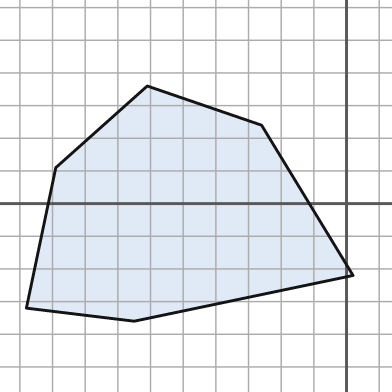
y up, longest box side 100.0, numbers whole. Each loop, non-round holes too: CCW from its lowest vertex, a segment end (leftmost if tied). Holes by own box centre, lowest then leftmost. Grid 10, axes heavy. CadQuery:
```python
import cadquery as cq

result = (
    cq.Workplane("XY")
    .moveTo(-65.0, -36.0)
    .lineTo(2.0, -22.0)
    .lineTo(-26.0, 24.0)
    .lineTo(-61.0, 36.0)
    .lineTo(-89.0, 11.0)
    .lineTo(-98.0, -32.0)
    .close()
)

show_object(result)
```